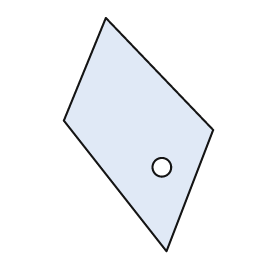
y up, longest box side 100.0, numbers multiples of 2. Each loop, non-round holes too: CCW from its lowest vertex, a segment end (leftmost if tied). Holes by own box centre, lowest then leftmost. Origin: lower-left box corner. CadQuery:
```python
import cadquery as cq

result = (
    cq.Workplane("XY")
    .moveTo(44.0, 0.0)
    .lineTo(64.0, 52.0)
    .lineTo(18.0, 100.0)
    .lineTo(0.0, 56.0)
    .close()
    .moveTo(42.0, 36.0)
    .circle(4.0)
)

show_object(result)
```